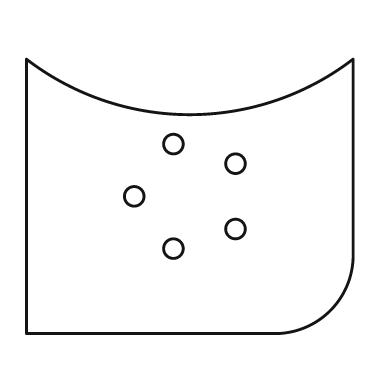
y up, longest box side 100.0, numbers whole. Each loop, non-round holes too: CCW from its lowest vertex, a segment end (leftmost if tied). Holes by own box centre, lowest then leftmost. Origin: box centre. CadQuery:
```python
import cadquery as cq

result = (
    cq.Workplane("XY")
    .moveTo(-50.0, -42.0)
    .lineTo(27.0, -42.0)
    .threePointArc((43.0, -35.0), (50.0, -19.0))
    .lineTo(50.0, 42.0)
    .threePointArc((0.0, 25.0), (-50.0, 42.0))
    .close()
    .moveTo(-5.0, -16.0)
    .circle(3.0)
    .moveTo(14.0, -10.0)
    .circle(3.0)
    .moveTo(-17.0, 0.0)
    .circle(3.0)
    .moveTo(14.0, 10.0)
    .circle(3.0)
    .moveTo(-5.0, 16.0)
    .circle(3.0)
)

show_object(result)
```